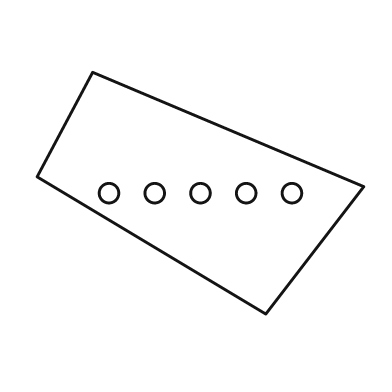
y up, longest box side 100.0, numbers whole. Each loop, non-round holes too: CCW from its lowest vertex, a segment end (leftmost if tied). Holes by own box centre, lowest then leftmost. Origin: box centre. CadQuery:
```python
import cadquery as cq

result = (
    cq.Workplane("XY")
    .moveTo(20.0, -37.0)
    .lineTo(50.0, 2.0)
    .lineTo(-33.0, 37.0)
    .lineTo(-50.0, 5.0)
    .close()
    .moveTo(-28.0, 0.0)
    .circle(3.0)
    .moveTo(-14.0, 0.0)
    .circle(3.0)
    .moveTo(0.0, 0.0)
    .circle(3.0)
    .moveTo(14.0, 0.0)
    .circle(3.0)
    .moveTo(28.0, 0.0)
    .circle(3.0)
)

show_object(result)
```